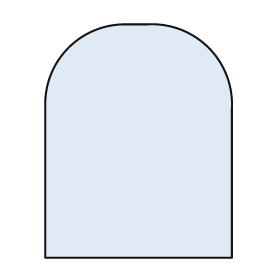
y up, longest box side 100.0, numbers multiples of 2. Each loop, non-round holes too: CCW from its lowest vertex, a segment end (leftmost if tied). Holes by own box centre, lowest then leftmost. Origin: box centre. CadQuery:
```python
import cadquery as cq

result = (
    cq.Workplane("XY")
    .moveTo(-40.0, -50.0)
    .lineTo(40.0, -50.0)
    .lineTo(40.0, 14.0)
    .threePointArc((30.0, 40.0), (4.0, 50.0))
    .lineTo(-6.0, 50.0)
    .threePointArc((-30.0, 40.0), (-40.0, 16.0))
    .close()
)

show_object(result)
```